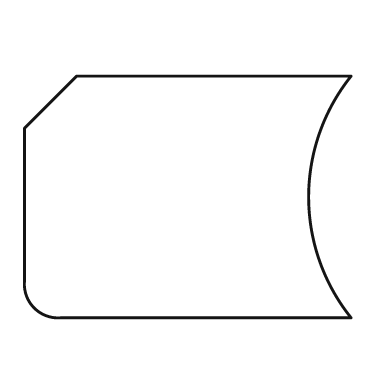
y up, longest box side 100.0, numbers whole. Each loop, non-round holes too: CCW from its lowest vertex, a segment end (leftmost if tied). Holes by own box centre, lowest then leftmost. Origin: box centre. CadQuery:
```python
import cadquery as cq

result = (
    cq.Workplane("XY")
    .moveTo(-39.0, -37.0)
    .lineTo(50.0, -37.0)
    .threePointArc((37.0, 0.0), (50.0, 37.0))
    .lineTo(-34.0, 37.0)
    .lineTo(-50.0, 21.0)
    .lineTo(-50.0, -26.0)
    .threePointArc((-47.0, -34.0), (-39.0, -37.0))
    .close()
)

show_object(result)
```